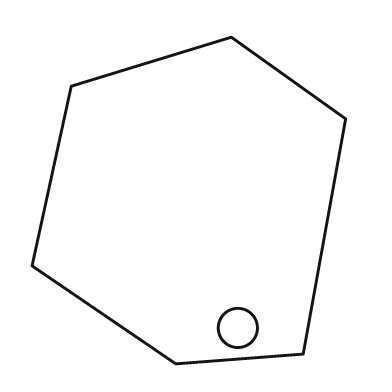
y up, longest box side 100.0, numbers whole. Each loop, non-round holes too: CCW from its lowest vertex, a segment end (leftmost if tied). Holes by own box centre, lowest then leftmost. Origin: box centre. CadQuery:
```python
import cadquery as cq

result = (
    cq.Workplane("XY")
    .moveTo(-4.0, -50.0)
    .lineTo(35.0, -47.0)
    .lineTo(48.0, 25.0)
    .lineTo(13.0, 50.0)
    .lineTo(-36.0, 35.0)
    .lineTo(-48.0, -20.0)
    .close()
    .moveTo(15.0, -39.0)
    .circle(6.0)
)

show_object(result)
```